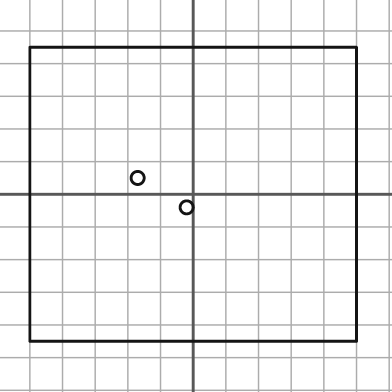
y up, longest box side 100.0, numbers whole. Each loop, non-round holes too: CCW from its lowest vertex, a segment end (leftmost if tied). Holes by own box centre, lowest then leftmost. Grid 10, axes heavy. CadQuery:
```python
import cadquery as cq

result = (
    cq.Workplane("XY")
    .moveTo(-50.0, -45.0)
    .lineTo(50.0, -45.0)
    .lineTo(50.0, 45.0)
    .lineTo(-50.0, 45.0)
    .close()
    .moveTo(-2.0, -4.0)
    .circle(2.0)
    .moveTo(-17.0, 5.0)
    .circle(2.0)
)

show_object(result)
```